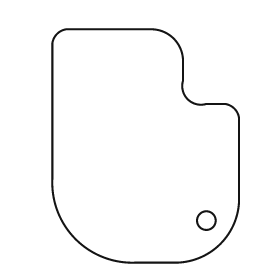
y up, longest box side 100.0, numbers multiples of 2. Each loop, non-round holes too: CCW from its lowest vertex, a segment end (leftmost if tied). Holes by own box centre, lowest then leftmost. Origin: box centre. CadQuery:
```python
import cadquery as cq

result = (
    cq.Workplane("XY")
    .moveTo(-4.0, -50.0)
    .lineTo(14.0, -50.0)
    .threePointArc((32.0, -42.0), (40.0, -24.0))
    .lineTo(40.0, 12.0)
    .threePointArc((38.0, 16.0), (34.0, 18.0))
    .lineTo(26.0, 18.0)
    .threePointArc((18.0, 20.0), (16.0, 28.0))
    .lineTo(16.0, 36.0)
    .threePointArc((12.0, 46.0), (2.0, 50.0))
    .lineTo(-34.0, 50.0)
    .threePointArc((-38.0, 48.0), (-40.0, 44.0))
    .lineTo(-40.0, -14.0)
    .threePointArc((-30.0, -40.0), (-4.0, -50.0))
    .close()
    .moveTo(26.0, -32.0)
    .circle(4.0)
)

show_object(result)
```